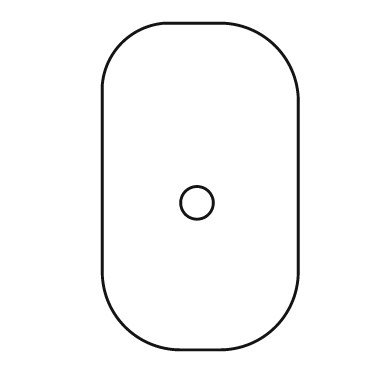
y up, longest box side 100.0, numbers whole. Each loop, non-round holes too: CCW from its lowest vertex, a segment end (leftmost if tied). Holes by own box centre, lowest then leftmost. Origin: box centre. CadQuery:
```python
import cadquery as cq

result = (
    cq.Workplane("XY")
    .moveTo(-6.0, -50.0)
    .lineTo(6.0, -50.0)
    .threePointArc((23.0, -43.0), (30.0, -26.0))
    .lineTo(30.0, 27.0)
    .threePointArc((23.0, 43.0), (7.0, 50.0))
    .lineTo(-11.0, 50.0)
    .threePointArc((-24.0, 44.0), (-30.0, 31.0))
    .lineTo(-30.0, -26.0)
    .threePointArc((-23.0, -43.0), (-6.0, -50.0))
    .close()
    .moveTo(-1.0, -5.0)
    .circle(5.0)
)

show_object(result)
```